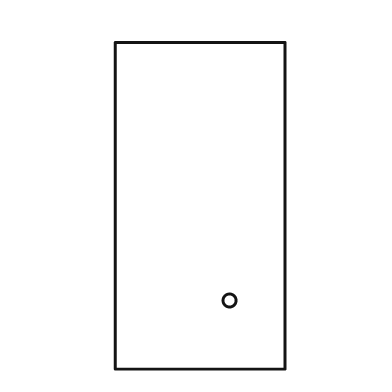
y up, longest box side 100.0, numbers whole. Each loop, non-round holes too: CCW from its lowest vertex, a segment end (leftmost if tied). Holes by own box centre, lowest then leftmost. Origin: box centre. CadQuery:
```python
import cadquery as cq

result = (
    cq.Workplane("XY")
    .moveTo(-26.0, -50.0)
    .lineTo(26.0, -50.0)
    .lineTo(26.0, 50.0)
    .lineTo(-26.0, 50.0)
    .close()
    .moveTo(9.0, -29.0)
    .circle(2.0)
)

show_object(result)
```